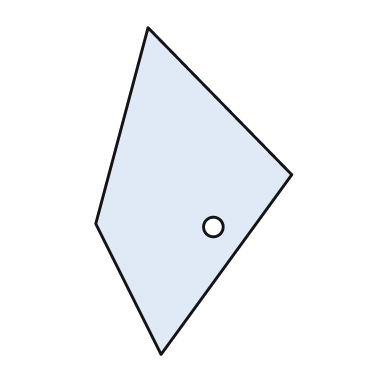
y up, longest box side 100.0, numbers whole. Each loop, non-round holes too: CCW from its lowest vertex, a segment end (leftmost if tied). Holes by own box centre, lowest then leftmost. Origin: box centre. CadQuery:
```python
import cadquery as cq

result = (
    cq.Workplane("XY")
    .moveTo(-10.0, -50.0)
    .lineTo(30.0, 5.0)
    .lineTo(-14.0, 50.0)
    .lineTo(-30.0, -10.0)
    .close()
    .moveTo(6.0, -11.0)
    .circle(3.0)
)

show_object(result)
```